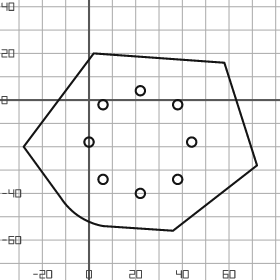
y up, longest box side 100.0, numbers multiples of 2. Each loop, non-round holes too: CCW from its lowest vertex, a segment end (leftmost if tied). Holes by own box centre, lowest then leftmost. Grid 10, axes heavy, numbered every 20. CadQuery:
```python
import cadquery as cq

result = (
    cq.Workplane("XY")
    .moveTo(36.0, -56.0)
    .lineTo(72.0, -28.0)
    .lineTo(58.0, 16.0)
    .lineTo(2.0, 20.0)
    .lineTo(-28.0, -20.0)
    .lineTo(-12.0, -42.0)
    .threePointArc((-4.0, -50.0), (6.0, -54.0))
    .close()
    .moveTo(22.0, -40.0)
    .circle(2.0)
    .moveTo(6.0, -34.0)
    .circle(2.0)
    .moveTo(38.0, -34.0)
    .circle(2.0)
    .moveTo(0.0, -18.0)
    .circle(2.0)
    .moveTo(44.0, -18.0)
    .circle(2.0)
    .moveTo(6.0, -2.0)
    .circle(2.0)
    .moveTo(38.0, -2.0)
    .circle(2.0)
    .moveTo(22.0, 4.0)
    .circle(2.0)
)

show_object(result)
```